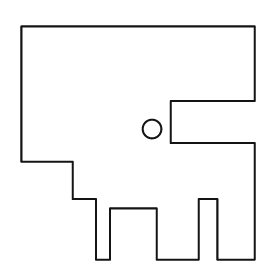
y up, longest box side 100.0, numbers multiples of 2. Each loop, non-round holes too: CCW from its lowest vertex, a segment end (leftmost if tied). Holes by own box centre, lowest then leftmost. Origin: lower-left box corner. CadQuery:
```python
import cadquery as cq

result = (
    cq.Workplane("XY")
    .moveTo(32.0, 0.0)
    .lineTo(38.0, 0.0)
    .lineTo(38.0, 22.0)
    .lineTo(58.0, 22.0)
    .lineTo(58.0, 0.0)
    .lineTo(76.0, 0.0)
    .lineTo(76.0, 26.0)
    .lineTo(84.0, 26.0)
    .lineTo(84.0, 0.0)
    .lineTo(100.0, 0.0)
    .lineTo(100.0, 50.0)
    .lineTo(64.0, 50.0)
    .lineTo(64.0, 68.0)
    .lineTo(100.0, 68.0)
    .lineTo(100.0, 100.0)
    .lineTo(0.0, 100.0)
    .lineTo(0.0, 42.0)
    .lineTo(22.0, 42.0)
    .lineTo(22.0, 26.0)
    .lineTo(32.0, 26.0)
    .close()
    .moveTo(56.0, 56.0)
    .circle(4.0)
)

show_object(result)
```